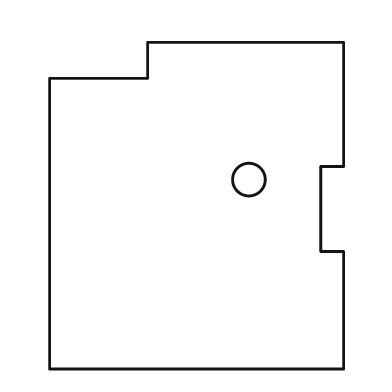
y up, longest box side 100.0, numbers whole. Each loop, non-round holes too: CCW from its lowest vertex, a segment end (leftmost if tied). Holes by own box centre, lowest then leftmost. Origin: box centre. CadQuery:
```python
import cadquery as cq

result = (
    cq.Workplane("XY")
    .moveTo(-45.0, -50.0)
    .lineTo(45.0, -50.0)
    .lineTo(45.0, -14.0)
    .lineTo(38.0, -14.0)
    .lineTo(38.0, 12.0)
    .lineTo(45.0, 12.0)
    .lineTo(45.0, 50.0)
    .lineTo(-15.0, 50.0)
    .lineTo(-15.0, 39.0)
    .lineTo(-45.0, 39.0)
    .close()
    .moveTo(16.0, 8.0)
    .circle(5.0)
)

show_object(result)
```